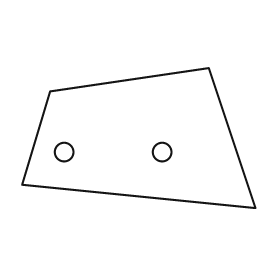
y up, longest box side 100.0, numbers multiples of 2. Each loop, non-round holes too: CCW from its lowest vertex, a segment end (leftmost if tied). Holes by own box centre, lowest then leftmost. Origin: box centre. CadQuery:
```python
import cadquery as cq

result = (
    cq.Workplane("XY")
    .moveTo(50.0, -30.0)
    .lineTo(30.0, 30.0)
    .lineTo(-38.0, 20.0)
    .lineTo(-50.0, -20.0)
    .close()
    .moveTo(-32.0, -6.0)
    .circle(4.0)
    .moveTo(10.0, -6.0)
    .circle(4.0)
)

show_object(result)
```